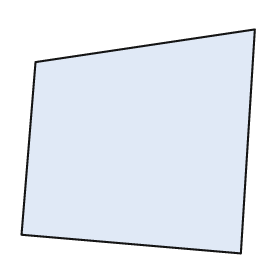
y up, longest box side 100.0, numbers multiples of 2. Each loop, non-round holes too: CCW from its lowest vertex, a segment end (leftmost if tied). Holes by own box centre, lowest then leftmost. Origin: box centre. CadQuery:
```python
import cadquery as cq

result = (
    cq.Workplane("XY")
    .moveTo(44.0, -48.0)
    .lineTo(50.0, 48.0)
    .lineTo(-44.0, 34.0)
    .lineTo(-50.0, -40.0)
    .close()
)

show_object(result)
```